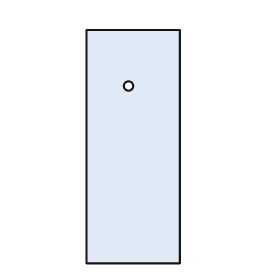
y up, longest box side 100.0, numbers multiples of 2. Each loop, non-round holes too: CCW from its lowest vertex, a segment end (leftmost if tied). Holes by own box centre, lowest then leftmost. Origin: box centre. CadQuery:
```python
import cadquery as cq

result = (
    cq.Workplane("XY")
    .moveTo(-20.0, -50.0)
    .lineTo(20.0, -50.0)
    .lineTo(20.0, 50.0)
    .lineTo(-20.0, 50.0)
    .close()
    .moveTo(-2.0, 26.0)
    .circle(2.0)
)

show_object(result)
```